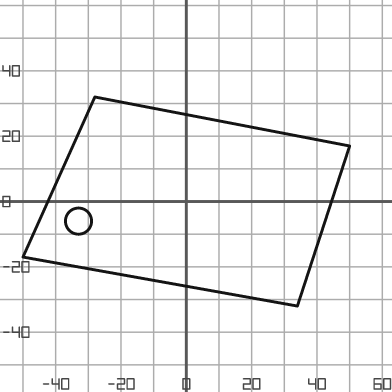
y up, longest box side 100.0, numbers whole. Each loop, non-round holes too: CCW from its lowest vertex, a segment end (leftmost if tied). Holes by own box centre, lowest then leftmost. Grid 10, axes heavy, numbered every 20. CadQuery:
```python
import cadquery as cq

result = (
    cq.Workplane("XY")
    .moveTo(34.0, -32.0)
    .lineTo(50.0, 17.0)
    .lineTo(-28.0, 32.0)
    .lineTo(-50.0, -17.0)
    .close()
    .moveTo(-33.0, -6.0)
    .circle(4.0)
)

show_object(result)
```